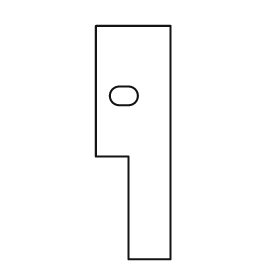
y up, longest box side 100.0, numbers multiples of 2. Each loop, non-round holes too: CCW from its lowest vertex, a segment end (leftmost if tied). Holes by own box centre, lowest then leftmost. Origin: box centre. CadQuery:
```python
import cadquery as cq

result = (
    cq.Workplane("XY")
    .moveTo(-2.0, -50.0)
    .lineTo(16.0, -50.0)
    .lineTo(16.0, 50.0)
    .lineTo(-16.0, 50.0)
    .lineTo(-16.0, -6.0)
    .lineTo(-2.0, -6.0)
    .close()
    .moveTo(-6.0, 16.0)
    .lineTo(-2.0, 16.0)
    .threePointArc((2.0, 20.0), (-2.0, 24.0))
    .lineTo(-6.0, 24.0)
    .threePointArc((-10.0, 20.0), (-6.0, 16.0))
    .close()
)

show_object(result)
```